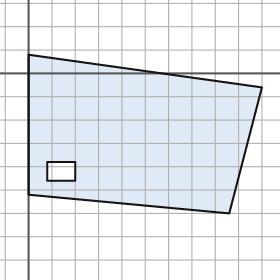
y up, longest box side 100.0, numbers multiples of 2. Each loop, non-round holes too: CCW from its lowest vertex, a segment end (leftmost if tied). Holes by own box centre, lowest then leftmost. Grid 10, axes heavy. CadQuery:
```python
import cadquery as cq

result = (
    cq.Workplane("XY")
    .moveTo(86.0, -60.0)
    .lineTo(100.0, -6.0)
    .lineTo(0.0, 8.0)
    .lineTo(0.0, -52.0)
    .close()
    .moveTo(8.0, -46.0)
    .lineTo(20.0, -46.0)
    .lineTo(20.0, -38.0)
    .lineTo(8.0, -38.0)
    .close()
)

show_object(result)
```